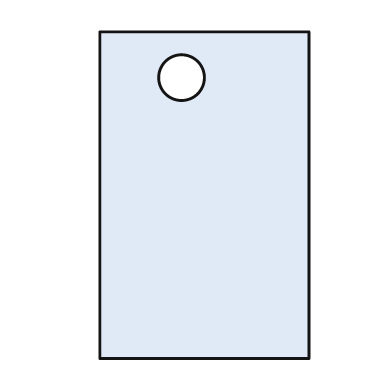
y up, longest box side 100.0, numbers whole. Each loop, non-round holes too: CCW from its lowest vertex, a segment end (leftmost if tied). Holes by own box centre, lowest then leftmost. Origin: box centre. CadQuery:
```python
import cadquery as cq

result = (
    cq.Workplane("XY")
    .moveTo(-32.0, -50.0)
    .lineTo(32.0, -50.0)
    .lineTo(32.0, 50.0)
    .lineTo(-32.0, 50.0)
    .close()
    .moveTo(-7.0, 36.0)
    .circle(7.0)
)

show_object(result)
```